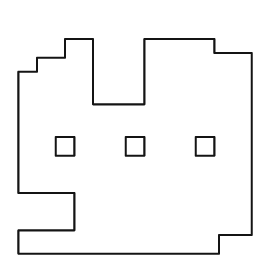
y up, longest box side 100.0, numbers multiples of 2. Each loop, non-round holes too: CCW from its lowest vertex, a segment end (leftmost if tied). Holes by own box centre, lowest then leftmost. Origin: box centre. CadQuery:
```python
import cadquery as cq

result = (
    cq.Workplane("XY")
    .moveTo(-50.0, -46.0)
    .lineTo(36.0, -46.0)
    .lineTo(36.0, -38.0)
    .lineTo(50.0, -38.0)
    .lineTo(50.0, 40.0)
    .lineTo(34.0, 40.0)
    .lineTo(34.0, 46.0)
    .lineTo(4.0, 46.0)
    .lineTo(4.0, 18.0)
    .lineTo(-18.0, 18.0)
    .lineTo(-18.0, 46.0)
    .lineTo(-30.0, 46.0)
    .lineTo(-30.0, 38.0)
    .lineTo(-42.0, 38.0)
    .lineTo(-42.0, 32.0)
    .lineTo(-50.0, 32.0)
    .lineTo(-50.0, -20.0)
    .lineTo(-26.0, -20.0)
    .lineTo(-26.0, -36.0)
    .lineTo(-50.0, -36.0)
    .close()
    .moveTo(-34.0, -4.0)
    .lineTo(-26.0, -4.0)
    .lineTo(-26.0, 4.0)
    .lineTo(-34.0, 4.0)
    .close()
    .moveTo(-4.0, -4.0)
    .lineTo(4.0, -4.0)
    .lineTo(4.0, 4.0)
    .lineTo(-4.0, 4.0)
    .close()
    .moveTo(26.0, -4.0)
    .lineTo(34.0, -4.0)
    .lineTo(34.0, 4.0)
    .lineTo(26.0, 4.0)
    .close()
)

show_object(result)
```